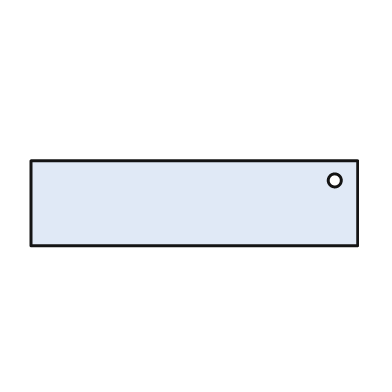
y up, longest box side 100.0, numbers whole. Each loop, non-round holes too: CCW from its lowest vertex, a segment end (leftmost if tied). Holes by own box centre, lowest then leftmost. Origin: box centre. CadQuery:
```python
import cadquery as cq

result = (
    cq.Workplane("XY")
    .moveTo(-50.0, -13.0)
    .lineTo(50.0, -13.0)
    .lineTo(50.0, 13.0)
    .lineTo(-50.0, 13.0)
    .close()
    .moveTo(43.0, 7.0)
    .circle(2.0)
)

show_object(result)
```